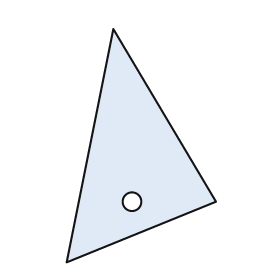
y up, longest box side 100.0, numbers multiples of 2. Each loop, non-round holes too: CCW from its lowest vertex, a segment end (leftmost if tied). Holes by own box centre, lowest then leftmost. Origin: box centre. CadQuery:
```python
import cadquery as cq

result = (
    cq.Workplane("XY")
    .moveTo(-32.0, -50.0)
    .lineTo(32.0, -24.0)
    .lineTo(-12.0, 50.0)
    .close()
    .moveTo(-4.0, -24.0)
    .circle(4.0)
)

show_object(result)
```